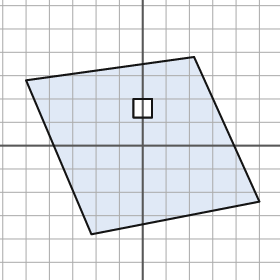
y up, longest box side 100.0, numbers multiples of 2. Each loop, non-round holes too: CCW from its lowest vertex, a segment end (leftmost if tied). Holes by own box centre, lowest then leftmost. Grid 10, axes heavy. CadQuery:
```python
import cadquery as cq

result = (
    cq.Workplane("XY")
    .moveTo(-22.0, -38.0)
    .lineTo(50.0, -24.0)
    .lineTo(22.0, 38.0)
    .lineTo(-50.0, 28.0)
    .close()
    .moveTo(-4.0, 12.0)
    .lineTo(4.0, 12.0)
    .lineTo(4.0, 20.0)
    .lineTo(-4.0, 20.0)
    .close()
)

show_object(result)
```